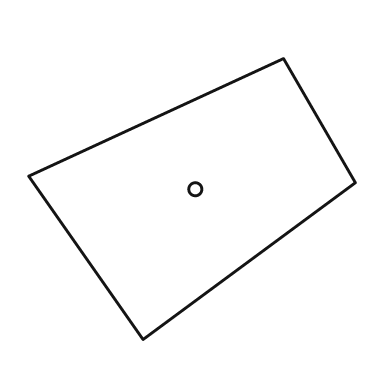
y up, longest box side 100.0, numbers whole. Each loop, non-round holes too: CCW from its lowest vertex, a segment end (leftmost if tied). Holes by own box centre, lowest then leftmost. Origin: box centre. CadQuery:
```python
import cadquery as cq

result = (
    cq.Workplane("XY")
    .moveTo(-15.0, -43.0)
    .lineTo(50.0, 5.0)
    .lineTo(28.0, 43.0)
    .lineTo(-50.0, 7.0)
    .close()
    .moveTo(1.0, 3.0)
    .circle(2.0)
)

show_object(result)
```